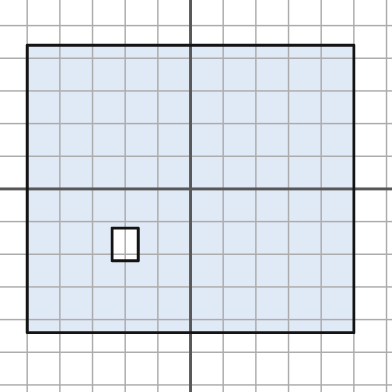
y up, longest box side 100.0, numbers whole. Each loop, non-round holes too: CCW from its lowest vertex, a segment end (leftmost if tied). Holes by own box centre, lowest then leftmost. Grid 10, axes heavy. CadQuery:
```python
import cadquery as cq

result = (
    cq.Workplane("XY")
    .moveTo(-50.0, -44.0)
    .lineTo(50.0, -44.0)
    .lineTo(50.0, 44.0)
    .lineTo(-50.0, 44.0)
    .close()
    .moveTo(-24.0, -22.0)
    .lineTo(-16.0, -22.0)
    .lineTo(-16.0, -12.0)
    .lineTo(-24.0, -12.0)
    .close()
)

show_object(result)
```